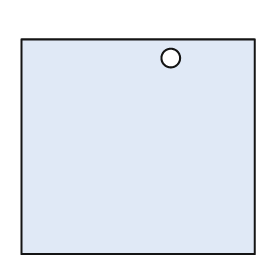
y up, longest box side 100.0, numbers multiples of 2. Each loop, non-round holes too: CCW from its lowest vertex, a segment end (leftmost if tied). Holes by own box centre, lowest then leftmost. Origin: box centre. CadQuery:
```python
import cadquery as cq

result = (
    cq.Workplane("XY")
    .moveTo(-50.0, -46.0)
    .lineTo(50.0, -46.0)
    .lineTo(50.0, 46.0)
    .lineTo(-50.0, 46.0)
    .close()
    .moveTo(14.0, 38.0)
    .circle(4.0)
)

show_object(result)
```